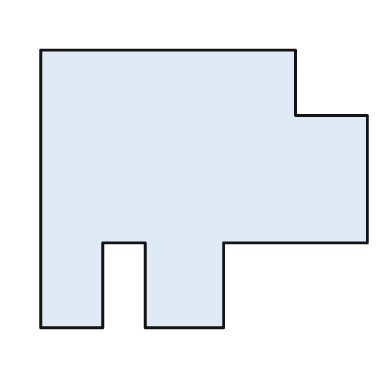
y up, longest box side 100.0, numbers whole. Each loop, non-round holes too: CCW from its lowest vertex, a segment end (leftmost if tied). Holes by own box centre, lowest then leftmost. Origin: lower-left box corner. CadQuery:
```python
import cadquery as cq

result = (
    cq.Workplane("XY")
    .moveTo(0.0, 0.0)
    .lineTo(19.0, 0.0)
    .lineTo(19.0, 26.0)
    .lineTo(32.0, 26.0)
    .lineTo(32.0, 0.0)
    .lineTo(56.0, 0.0)
    .lineTo(56.0, 26.0)
    .lineTo(100.0, 26.0)
    .lineTo(100.0, 65.0)
    .lineTo(78.0, 65.0)
    .lineTo(78.0, 85.0)
    .lineTo(0.0, 85.0)
    .close()
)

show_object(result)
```